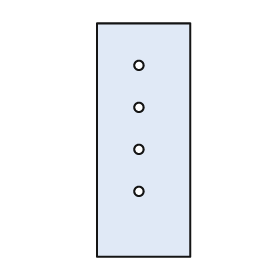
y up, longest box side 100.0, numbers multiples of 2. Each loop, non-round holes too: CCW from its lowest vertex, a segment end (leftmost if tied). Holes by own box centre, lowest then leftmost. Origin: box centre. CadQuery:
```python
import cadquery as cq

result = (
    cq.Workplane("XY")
    .moveTo(-20.0, -50.0)
    .lineTo(20.0, -50.0)
    .lineTo(20.0, 50.0)
    .lineTo(-20.0, 50.0)
    .close()
    .moveTo(-2.0, -22.0)
    .circle(2.0)
    .moveTo(-2.0, -4.0)
    .circle(2.0)
    .moveTo(-2.0, 14.0)
    .circle(2.0)
    .moveTo(-2.0, 32.0)
    .circle(2.0)
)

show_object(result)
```